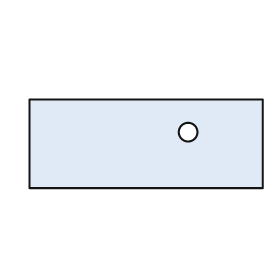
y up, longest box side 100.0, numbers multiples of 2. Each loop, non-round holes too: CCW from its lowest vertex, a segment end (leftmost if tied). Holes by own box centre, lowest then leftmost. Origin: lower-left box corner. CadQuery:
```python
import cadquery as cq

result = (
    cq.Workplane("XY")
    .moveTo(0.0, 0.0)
    .lineTo(100.0, 0.0)
    .lineTo(100.0, 38.0)
    .lineTo(0.0, 38.0)
    .close()
    .moveTo(68.0, 24.0)
    .circle(4.0)
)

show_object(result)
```